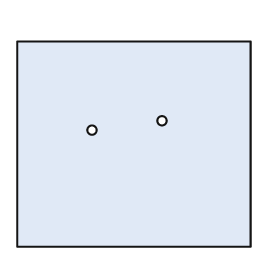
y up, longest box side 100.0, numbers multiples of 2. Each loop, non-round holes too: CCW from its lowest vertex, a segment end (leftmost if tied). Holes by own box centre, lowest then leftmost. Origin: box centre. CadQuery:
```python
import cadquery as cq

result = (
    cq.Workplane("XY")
    .moveTo(-50.0, -44.0)
    .lineTo(50.0, -44.0)
    .lineTo(50.0, 44.0)
    .lineTo(-50.0, 44.0)
    .close()
    .moveTo(-18.0, 6.0)
    .circle(2.0)
    .moveTo(12.0, 10.0)
    .circle(2.0)
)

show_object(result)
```